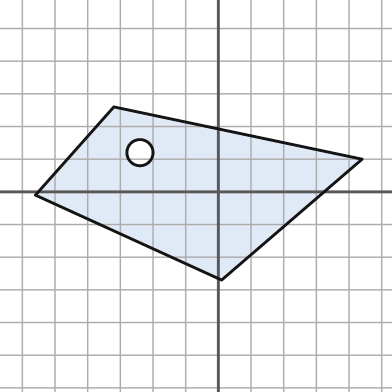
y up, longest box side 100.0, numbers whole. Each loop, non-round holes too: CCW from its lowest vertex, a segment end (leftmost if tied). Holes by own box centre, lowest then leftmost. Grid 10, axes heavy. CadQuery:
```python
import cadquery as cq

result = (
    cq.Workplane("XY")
    .moveTo(1.0, -27.0)
    .lineTo(44.0, 10.0)
    .lineTo(-32.0, 26.0)
    .lineTo(-56.0, -1.0)
    .close()
    .moveTo(-24.0, 12.0)
    .circle(4.0)
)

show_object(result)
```